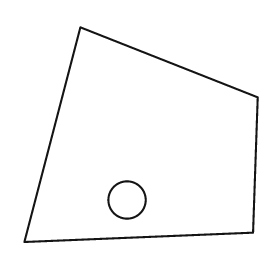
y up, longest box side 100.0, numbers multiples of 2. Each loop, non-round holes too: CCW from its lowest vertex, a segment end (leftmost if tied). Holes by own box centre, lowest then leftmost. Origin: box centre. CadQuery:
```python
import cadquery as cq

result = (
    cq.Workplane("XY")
    .moveTo(-50.0, -46.0)
    .lineTo(48.0, -42.0)
    .lineTo(50.0, 16.0)
    .lineTo(-26.0, 46.0)
    .close()
    .moveTo(-6.0, -28.0)
    .circle(8.0)
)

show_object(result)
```